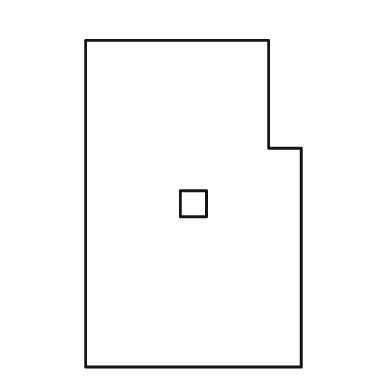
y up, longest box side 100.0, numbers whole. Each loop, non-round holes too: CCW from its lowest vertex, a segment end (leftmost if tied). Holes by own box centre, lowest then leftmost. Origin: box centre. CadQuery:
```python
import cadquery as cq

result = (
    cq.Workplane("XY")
    .moveTo(-33.0, -50.0)
    .lineTo(33.0, -50.0)
    .lineTo(33.0, 17.0)
    .lineTo(23.0, 17.0)
    .lineTo(23.0, 50.0)
    .lineTo(-33.0, 50.0)
    .close()
    .moveTo(-4.0, -4.0)
    .lineTo(4.0, -4.0)
    .lineTo(4.0, 4.0)
    .lineTo(-4.0, 4.0)
    .close()
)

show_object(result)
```